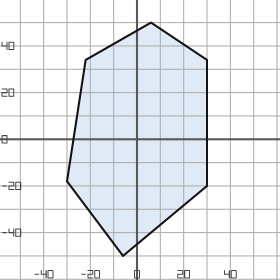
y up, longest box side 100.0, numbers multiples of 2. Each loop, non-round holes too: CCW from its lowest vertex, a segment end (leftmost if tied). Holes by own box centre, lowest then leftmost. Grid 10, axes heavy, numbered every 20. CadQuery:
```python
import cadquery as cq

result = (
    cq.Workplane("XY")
    .moveTo(-6.0, -50.0)
    .lineTo(30.0, -20.0)
    .lineTo(30.0, 34.0)
    .lineTo(6.0, 50.0)
    .lineTo(-22.0, 34.0)
    .lineTo(-30.0, -18.0)
    .close()
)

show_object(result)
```